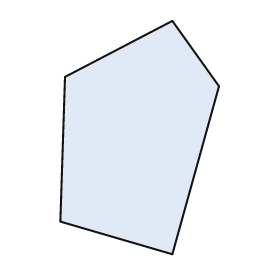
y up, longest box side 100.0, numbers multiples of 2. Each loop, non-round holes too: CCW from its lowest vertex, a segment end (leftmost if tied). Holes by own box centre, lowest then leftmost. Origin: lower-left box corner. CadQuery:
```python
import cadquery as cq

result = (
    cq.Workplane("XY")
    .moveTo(48.0, 0.0)
    .lineTo(68.0, 72.0)
    .lineTo(48.0, 100.0)
    .lineTo(2.0, 76.0)
    .lineTo(0.0, 14.0)
    .close()
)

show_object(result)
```